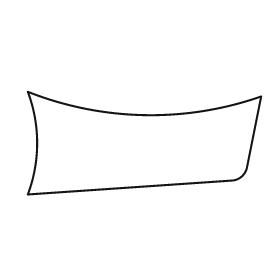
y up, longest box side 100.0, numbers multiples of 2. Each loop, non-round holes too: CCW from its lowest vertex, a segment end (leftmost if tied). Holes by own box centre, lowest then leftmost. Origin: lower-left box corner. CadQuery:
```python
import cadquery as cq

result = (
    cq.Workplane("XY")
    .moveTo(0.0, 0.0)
    .lineTo(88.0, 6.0)
    .threePointArc((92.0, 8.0), (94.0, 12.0))
    .lineTo(100.0, 42.0)
    .threePointArc((50.0, 34.0), (0.0, 44.0))
    .threePointArc((4.0, 22.0), (0.0, 0.0))
    .close()
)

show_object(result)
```